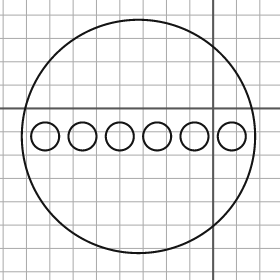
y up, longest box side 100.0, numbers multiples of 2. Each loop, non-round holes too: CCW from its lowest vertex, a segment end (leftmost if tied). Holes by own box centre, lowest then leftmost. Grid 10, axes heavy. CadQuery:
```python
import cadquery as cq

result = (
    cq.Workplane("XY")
    .moveTo(-32.0, -12.0)
    .circle(50.0)
    .moveTo(-72.0, -12.0)
    .circle(6.0)
    .moveTo(-56.0, -12.0)
    .circle(6.0)
    .moveTo(-40.0, -12.0)
    .circle(6.0)
    .moveTo(-24.0, -12.0)
    .circle(6.0)
    .moveTo(-8.0, -12.0)
    .circle(6.0)
    .moveTo(8.0, -12.0)
    .circle(6.0)
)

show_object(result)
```